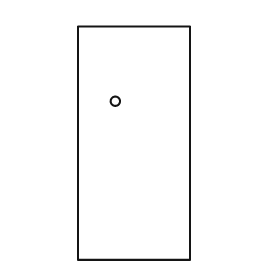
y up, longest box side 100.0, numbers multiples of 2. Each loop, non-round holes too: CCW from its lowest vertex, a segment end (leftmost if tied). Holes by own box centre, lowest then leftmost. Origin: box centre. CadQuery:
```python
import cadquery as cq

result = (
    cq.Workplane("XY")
    .moveTo(-24.0, -50.0)
    .lineTo(24.0, -50.0)
    .lineTo(24.0, 50.0)
    .lineTo(-24.0, 50.0)
    .close()
    .moveTo(-8.0, 18.0)
    .circle(2.0)
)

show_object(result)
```